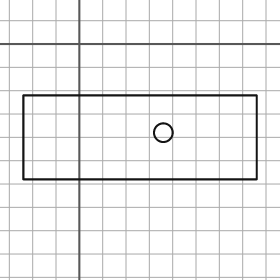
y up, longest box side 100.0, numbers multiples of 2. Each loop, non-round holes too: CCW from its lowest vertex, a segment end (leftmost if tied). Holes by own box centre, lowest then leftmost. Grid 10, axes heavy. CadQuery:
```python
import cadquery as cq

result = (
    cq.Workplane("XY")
    .moveTo(-24.0, -58.0)
    .lineTo(76.0, -58.0)
    .lineTo(76.0, -22.0)
    .lineTo(-24.0, -22.0)
    .close()
    .moveTo(36.0, -38.0)
    .circle(4.0)
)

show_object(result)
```